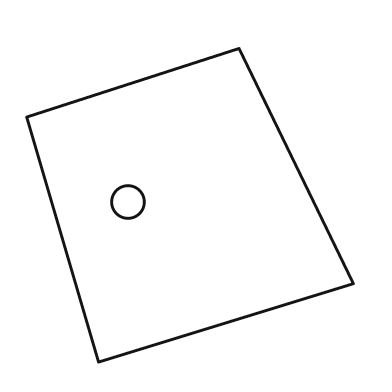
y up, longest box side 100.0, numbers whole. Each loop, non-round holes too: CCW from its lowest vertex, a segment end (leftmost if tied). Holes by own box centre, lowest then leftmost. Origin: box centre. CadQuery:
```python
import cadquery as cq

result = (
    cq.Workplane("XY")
    .moveTo(-28.0, -48.0)
    .lineTo(50.0, -24.0)
    .lineTo(15.0, 48.0)
    .lineTo(-50.0, 27.0)
    .close()
    .moveTo(-19.0, 1.0)
    .circle(5.0)
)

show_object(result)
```